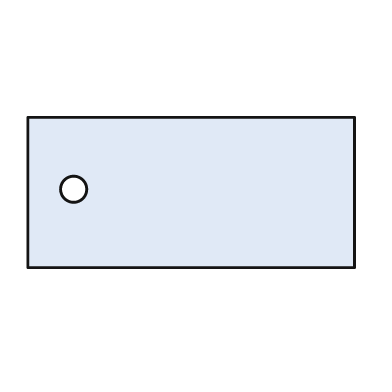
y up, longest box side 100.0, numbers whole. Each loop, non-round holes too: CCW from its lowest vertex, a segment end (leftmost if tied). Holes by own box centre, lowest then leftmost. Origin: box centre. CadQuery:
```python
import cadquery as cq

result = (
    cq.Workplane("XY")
    .moveTo(-50.0, -23.0)
    .lineTo(50.0, -23.0)
    .lineTo(50.0, 23.0)
    .lineTo(-50.0, 23.0)
    .close()
    .moveTo(-36.0, 1.0)
    .circle(4.0)
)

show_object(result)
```